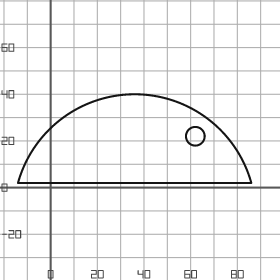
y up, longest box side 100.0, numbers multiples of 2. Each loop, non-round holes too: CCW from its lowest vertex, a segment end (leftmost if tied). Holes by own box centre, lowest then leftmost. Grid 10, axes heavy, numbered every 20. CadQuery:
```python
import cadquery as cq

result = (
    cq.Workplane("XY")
    .moveTo(-14.0, 2.0)
    .lineTo(86.0, 2.0)
    .threePointArc((36.0, 40.0), (-14.0, 2.0))
    .close()
    .moveTo(62.0, 22.0)
    .circle(4.0)
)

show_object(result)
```